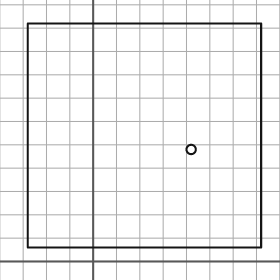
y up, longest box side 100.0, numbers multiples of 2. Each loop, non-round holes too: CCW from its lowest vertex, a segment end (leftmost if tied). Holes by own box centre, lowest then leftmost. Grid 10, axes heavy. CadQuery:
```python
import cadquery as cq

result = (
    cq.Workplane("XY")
    .moveTo(-28.0, 6.0)
    .lineTo(72.0, 6.0)
    .lineTo(72.0, 102.0)
    .lineTo(-28.0, 102.0)
    .close()
    .moveTo(42.0, 48.0)
    .circle(2.0)
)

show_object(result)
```